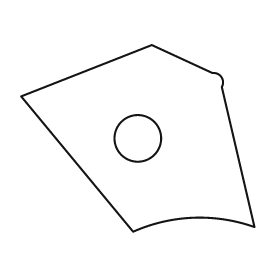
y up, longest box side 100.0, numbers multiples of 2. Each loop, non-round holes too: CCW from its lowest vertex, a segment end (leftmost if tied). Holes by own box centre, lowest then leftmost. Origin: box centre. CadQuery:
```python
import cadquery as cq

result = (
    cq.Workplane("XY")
    .moveTo(-2.0, -40.0)
    .threePointArc((24.0, -34.0), (50.0, -38.0))
    .lineTo(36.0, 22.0)
    .threePointArc((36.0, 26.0), (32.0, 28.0))
    .lineTo(6.0, 40.0)
    .lineTo(-50.0, 18.0)
    .close()
    .moveTo(0.0, 0.0)
    .circle(10.0)
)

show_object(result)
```